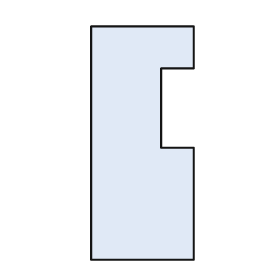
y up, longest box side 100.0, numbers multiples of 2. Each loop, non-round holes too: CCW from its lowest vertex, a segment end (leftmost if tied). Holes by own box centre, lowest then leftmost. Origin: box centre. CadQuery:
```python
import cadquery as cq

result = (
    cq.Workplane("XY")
    .moveTo(-22.0, -50.0)
    .lineTo(22.0, -50.0)
    .lineTo(22.0, -2.0)
    .lineTo(8.0, -2.0)
    .lineTo(8.0, 32.0)
    .lineTo(22.0, 32.0)
    .lineTo(22.0, 50.0)
    .lineTo(-22.0, 50.0)
    .close()
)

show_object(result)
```